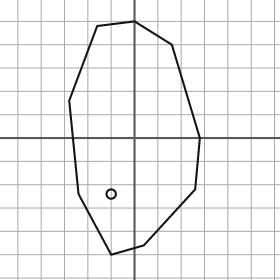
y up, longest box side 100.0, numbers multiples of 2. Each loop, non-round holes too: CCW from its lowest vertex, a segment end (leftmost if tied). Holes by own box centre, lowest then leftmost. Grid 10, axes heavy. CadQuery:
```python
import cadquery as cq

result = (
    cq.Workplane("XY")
    .moveTo(-10.0, -50.0)
    .lineTo(4.0, -46.0)
    .lineTo(26.0, -22.0)
    .lineTo(28.0, 0.0)
    .lineTo(16.0, 40.0)
    .lineTo(0.0, 50.0)
    .lineTo(-16.0, 48.0)
    .lineTo(-28.0, 16.0)
    .lineTo(-24.0, -24.0)
    .close()
    .moveTo(-10.0, -24.0)
    .circle(2.0)
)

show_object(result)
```